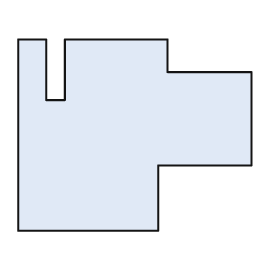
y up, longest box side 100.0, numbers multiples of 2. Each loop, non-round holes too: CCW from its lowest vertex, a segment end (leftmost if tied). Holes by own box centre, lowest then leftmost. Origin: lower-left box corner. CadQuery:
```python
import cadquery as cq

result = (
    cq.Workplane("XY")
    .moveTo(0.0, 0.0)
    .lineTo(60.0, 0.0)
    .lineTo(60.0, 28.0)
    .lineTo(100.0, 28.0)
    .lineTo(100.0, 68.0)
    .lineTo(64.0, 68.0)
    .lineTo(64.0, 82.0)
    .lineTo(20.0, 82.0)
    .lineTo(20.0, 56.0)
    .lineTo(12.0, 56.0)
    .lineTo(12.0, 82.0)
    .lineTo(0.0, 82.0)
    .close()
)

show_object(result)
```